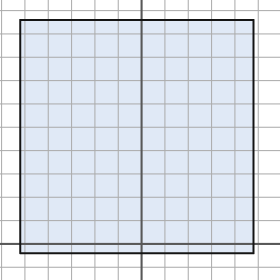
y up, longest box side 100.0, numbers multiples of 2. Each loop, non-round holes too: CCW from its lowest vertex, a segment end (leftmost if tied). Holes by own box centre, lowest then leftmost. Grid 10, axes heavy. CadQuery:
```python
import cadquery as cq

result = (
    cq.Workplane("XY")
    .moveTo(-52.0, -4.0)
    .lineTo(48.0, -4.0)
    .lineTo(48.0, 96.0)
    .lineTo(-52.0, 96.0)
    .close()
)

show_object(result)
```